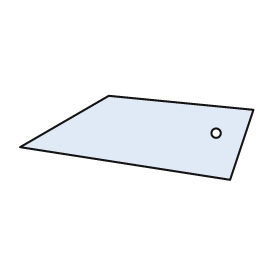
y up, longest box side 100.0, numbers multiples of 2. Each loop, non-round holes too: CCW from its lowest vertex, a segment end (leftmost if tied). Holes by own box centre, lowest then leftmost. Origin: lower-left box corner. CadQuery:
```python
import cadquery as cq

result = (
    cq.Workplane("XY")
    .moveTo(90.0, 0.0)
    .lineTo(100.0, 30.0)
    .lineTo(38.0, 36.0)
    .lineTo(0.0, 14.0)
    .close()
    .moveTo(84.0, 20.0)
    .circle(2.0)
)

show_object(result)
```